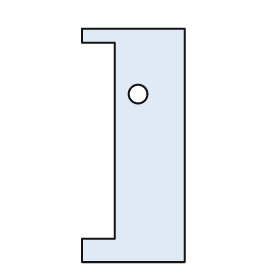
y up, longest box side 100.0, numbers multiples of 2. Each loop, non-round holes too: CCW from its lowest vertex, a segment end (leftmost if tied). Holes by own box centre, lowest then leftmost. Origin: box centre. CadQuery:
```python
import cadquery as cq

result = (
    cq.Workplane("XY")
    .moveTo(-22.0, -50.0)
    .lineTo(22.0, -50.0)
    .lineTo(22.0, 50.0)
    .lineTo(-22.0, 50.0)
    .lineTo(-22.0, 44.0)
    .lineTo(-8.0, 44.0)
    .lineTo(-8.0, -40.0)
    .lineTo(-22.0, -40.0)
    .close()
    .moveTo(2.0, 22.0)
    .circle(4.0)
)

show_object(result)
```